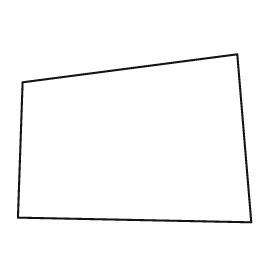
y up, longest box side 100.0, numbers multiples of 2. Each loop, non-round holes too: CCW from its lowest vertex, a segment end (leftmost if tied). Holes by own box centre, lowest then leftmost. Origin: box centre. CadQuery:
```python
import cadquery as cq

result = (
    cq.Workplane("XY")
    .moveTo(50.0, -36.0)
    .lineTo(44.0, 36.0)
    .lineTo(-48.0, 24.0)
    .lineTo(-50.0, -34.0)
    .close()
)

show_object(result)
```